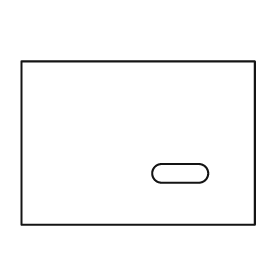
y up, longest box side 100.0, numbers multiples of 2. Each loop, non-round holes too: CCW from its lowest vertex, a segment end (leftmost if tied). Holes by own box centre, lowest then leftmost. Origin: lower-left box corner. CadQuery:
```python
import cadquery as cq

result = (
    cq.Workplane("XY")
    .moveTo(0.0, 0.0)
    .lineTo(100.0, 0.0)
    .lineTo(100.0, 70.0)
    .lineTo(0.0, 70.0)
    .close()
    .moveTo(60.0, 18.0)
    .lineTo(76.0, 18.0)
    .threePointArc((80.0, 22.0), (76.0, 26.0))
    .lineTo(60.0, 26.0)
    .threePointArc((56.0, 22.0), (60.0, 18.0))
    .close()
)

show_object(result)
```